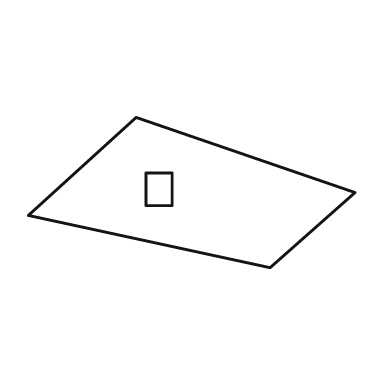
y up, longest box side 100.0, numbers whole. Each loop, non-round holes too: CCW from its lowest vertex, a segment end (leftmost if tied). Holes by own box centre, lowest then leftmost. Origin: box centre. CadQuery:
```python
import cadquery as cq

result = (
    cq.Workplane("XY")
    .moveTo(24.0, -23.0)
    .lineTo(50.0, 0.0)
    .lineTo(-17.0, 23.0)
    .lineTo(-50.0, -7.0)
    .close()
    .moveTo(-14.0, -4.0)
    .lineTo(-6.0, -4.0)
    .lineTo(-6.0, 6.0)
    .lineTo(-14.0, 6.0)
    .close()
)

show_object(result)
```